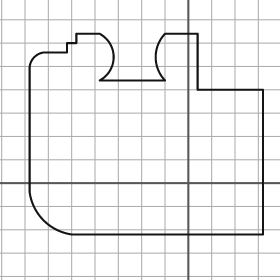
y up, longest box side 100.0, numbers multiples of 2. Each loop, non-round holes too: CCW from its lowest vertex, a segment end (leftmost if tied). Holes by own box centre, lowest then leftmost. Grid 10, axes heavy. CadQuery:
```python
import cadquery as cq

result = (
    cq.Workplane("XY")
    .moveTo(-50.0, -22.0)
    .lineTo(32.0, -22.0)
    .lineTo(32.0, 40.0)
    .lineTo(4.0, 40.0)
    .lineTo(4.0, 64.0)
    .lineTo(-10.0, 64.0)
    .threePointArc((-14.0, 54.0), (-10.0, 44.0))
    .lineTo(-38.0, 44.0)
    .threePointArc((-32.0, 54.0), (-38.0, 64.0))
    .lineTo(-48.0, 64.0)
    .lineTo(-48.0, 60.0)
    .lineTo(-52.0, 60.0)
    .lineTo(-52.0, 56.0)
    .lineTo(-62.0, 56.0)
    .threePointArc((-66.0, 54.0), (-68.0, 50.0))
    .lineTo(-68.0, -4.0)
    .threePointArc((-62.0, -16.0), (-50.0, -22.0))
    .close()
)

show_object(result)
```